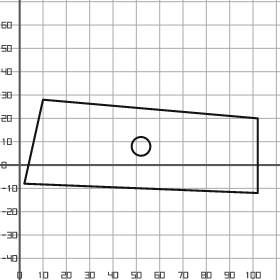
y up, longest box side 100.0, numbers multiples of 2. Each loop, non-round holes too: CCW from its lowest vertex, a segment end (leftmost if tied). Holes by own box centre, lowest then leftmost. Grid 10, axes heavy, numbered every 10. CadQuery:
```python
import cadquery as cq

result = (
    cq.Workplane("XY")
    .moveTo(102.0, -12.0)
    .lineTo(102.0, 20.0)
    .lineTo(10.0, 28.0)
    .lineTo(2.0, -8.0)
    .close()
    .moveTo(52.0, 8.0)
    .circle(4.0)
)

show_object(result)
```